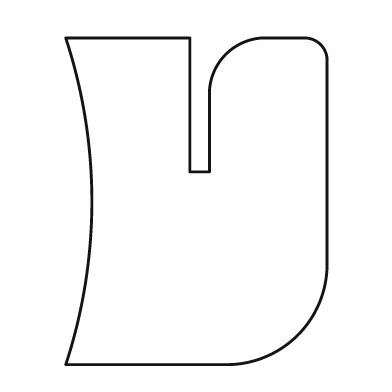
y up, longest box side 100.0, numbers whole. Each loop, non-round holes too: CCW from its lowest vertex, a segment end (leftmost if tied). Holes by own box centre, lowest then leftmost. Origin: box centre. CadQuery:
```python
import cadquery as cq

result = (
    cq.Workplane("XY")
    .moveTo(-40.0, -50.0)
    .lineTo(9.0, -50.0)
    .threePointArc((31.0, -41.0), (40.0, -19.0))
    .lineTo(40.0, 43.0)
    .threePointArc((38.0, 48.0), (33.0, 50.0))
    .lineTo(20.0, 50.0)
    .threePointArc((9.0, 45.0), (4.0, 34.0))
    .lineTo(4.0, 9.0)
    .lineTo(-2.0, 9.0)
    .lineTo(-2.0, 50.0)
    .lineTo(-40.0, 50.0)
    .threePointArc((-32.0, 0.0), (-40.0, -50.0))
    .close()
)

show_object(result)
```